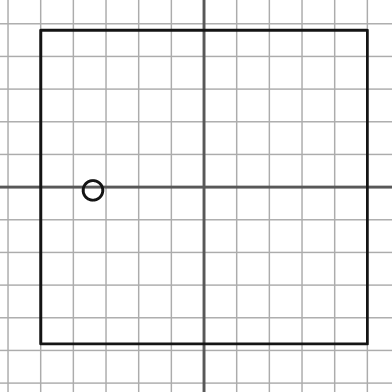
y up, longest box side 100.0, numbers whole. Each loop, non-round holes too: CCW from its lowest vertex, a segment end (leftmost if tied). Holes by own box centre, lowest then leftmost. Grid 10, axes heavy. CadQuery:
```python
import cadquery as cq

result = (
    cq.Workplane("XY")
    .moveTo(-50.0, -48.0)
    .lineTo(50.0, -48.0)
    .lineTo(50.0, 48.0)
    .lineTo(-50.0, 48.0)
    .close()
    .moveTo(-34.0, -1.0)
    .circle(3.0)
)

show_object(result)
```